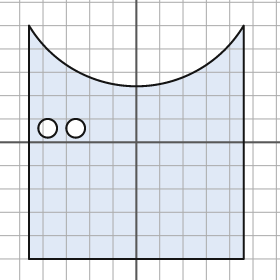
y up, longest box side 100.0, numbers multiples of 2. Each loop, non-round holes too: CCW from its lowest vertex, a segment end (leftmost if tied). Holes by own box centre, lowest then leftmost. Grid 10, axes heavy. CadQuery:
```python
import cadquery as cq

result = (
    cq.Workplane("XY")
    .moveTo(-46.0, -50.0)
    .lineTo(46.0, -50.0)
    .lineTo(46.0, 50.0)
    .threePointArc((0.0, 24.0), (-46.0, 50.0))
    .close()
    .moveTo(-38.0, 6.0)
    .circle(4.0)
    .moveTo(-26.0, 6.0)
    .circle(4.0)
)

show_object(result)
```